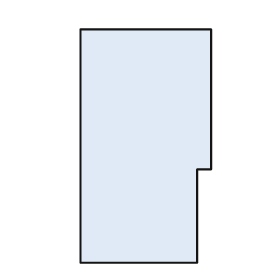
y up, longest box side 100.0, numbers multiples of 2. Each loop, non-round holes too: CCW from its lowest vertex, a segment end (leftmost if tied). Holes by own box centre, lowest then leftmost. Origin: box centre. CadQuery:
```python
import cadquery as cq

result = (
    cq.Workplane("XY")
    .moveTo(-28.0, -50.0)
    .lineTo(22.0, -50.0)
    .lineTo(22.0, -10.0)
    .lineTo(28.0, -10.0)
    .lineTo(28.0, 50.0)
    .lineTo(-28.0, 50.0)
    .close()
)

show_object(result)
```